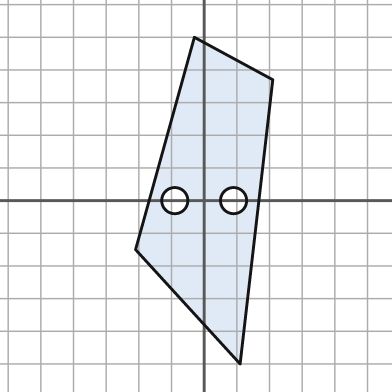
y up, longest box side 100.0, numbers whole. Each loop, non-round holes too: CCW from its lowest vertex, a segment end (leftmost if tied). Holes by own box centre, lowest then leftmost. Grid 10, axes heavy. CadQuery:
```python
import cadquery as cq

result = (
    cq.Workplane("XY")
    .moveTo(11.0, -50.0)
    .lineTo(21.0, 37.0)
    .lineTo(-3.0, 50.0)
    .lineTo(-21.0, -15.0)
    .close()
    .moveTo(-9.0, 0.0)
    .circle(4.0)
    .moveTo(9.0, 0.0)
    .circle(4.0)
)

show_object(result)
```